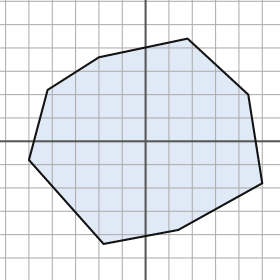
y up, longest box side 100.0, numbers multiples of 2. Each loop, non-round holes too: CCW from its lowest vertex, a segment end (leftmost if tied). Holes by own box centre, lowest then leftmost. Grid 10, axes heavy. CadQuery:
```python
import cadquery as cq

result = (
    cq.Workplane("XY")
    .moveTo(-18.0, -44.0)
    .lineTo(14.0, -38.0)
    .lineTo(50.0, -18.0)
    .lineTo(44.0, 20.0)
    .lineTo(18.0, 44.0)
    .lineTo(-20.0, 36.0)
    .lineTo(-42.0, 22.0)
    .lineTo(-50.0, -8.0)
    .close()
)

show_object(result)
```